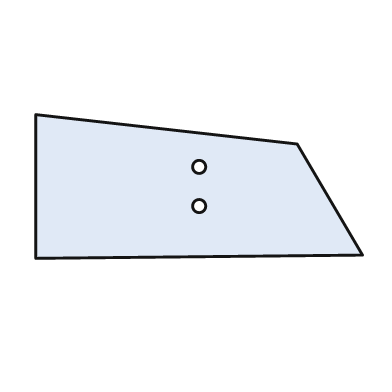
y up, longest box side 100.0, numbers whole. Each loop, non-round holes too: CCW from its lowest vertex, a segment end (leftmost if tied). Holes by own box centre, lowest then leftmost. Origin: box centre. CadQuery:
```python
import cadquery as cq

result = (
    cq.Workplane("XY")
    .moveTo(-50.0, -22.0)
    .lineTo(50.0, -21.0)
    .lineTo(30.0, 13.0)
    .lineTo(-50.0, 22.0)
    .close()
    .moveTo(0.0, -6.0)
    .circle(2.0)
    .moveTo(0.0, 6.0)
    .circle(2.0)
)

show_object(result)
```